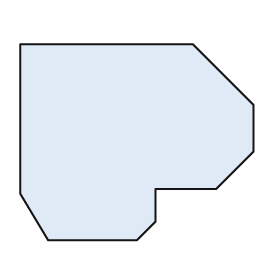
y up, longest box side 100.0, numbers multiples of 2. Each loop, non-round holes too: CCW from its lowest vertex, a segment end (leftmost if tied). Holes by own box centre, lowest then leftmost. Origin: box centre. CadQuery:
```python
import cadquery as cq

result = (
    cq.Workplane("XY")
    .moveTo(-38.0, -42.0)
    .lineTo(0.0, -42.0)
    .lineTo(8.0, -34.0)
    .lineTo(8.0, -20.0)
    .lineTo(34.0, -20.0)
    .lineTo(50.0, -4.0)
    .lineTo(50.0, 16.0)
    .lineTo(24.0, 42.0)
    .lineTo(-50.0, 42.0)
    .lineTo(-50.0, -22.0)
    .close()
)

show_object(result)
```